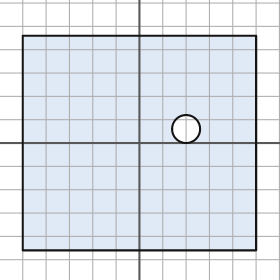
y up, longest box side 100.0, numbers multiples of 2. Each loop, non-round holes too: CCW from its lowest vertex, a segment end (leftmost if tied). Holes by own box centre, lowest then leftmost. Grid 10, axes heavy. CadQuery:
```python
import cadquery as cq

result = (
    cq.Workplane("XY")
    .moveTo(-50.0, -46.0)
    .lineTo(50.0, -46.0)
    .lineTo(50.0, 46.0)
    .lineTo(-50.0, 46.0)
    .close()
    .moveTo(20.0, 6.0)
    .circle(6.0)
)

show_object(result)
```